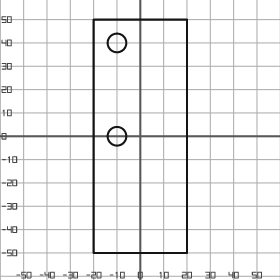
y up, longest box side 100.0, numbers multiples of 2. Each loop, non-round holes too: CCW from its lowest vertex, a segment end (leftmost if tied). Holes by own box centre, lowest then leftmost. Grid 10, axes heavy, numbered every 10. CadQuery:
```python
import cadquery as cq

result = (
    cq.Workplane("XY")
    .moveTo(-20.0, -50.0)
    .lineTo(20.0, -50.0)
    .lineTo(20.0, 50.0)
    .lineTo(-20.0, 50.0)
    .close()
    .moveTo(-10.0, 0.0)
    .circle(4.0)
    .moveTo(-10.0, 40.0)
    .circle(4.0)
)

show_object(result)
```